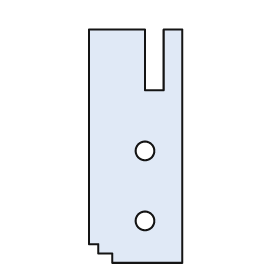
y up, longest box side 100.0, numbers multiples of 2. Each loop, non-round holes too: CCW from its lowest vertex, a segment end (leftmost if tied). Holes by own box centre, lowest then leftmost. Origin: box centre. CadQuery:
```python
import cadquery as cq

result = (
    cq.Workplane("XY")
    .moveTo(-10.0, -50.0)
    .lineTo(20.0, -50.0)
    .lineTo(20.0, 50.0)
    .lineTo(12.0, 50.0)
    .lineTo(12.0, 24.0)
    .lineTo(4.0, 24.0)
    .lineTo(4.0, 50.0)
    .lineTo(-20.0, 50.0)
    .lineTo(-20.0, -42.0)
    .lineTo(-16.0, -42.0)
    .lineTo(-16.0, -46.0)
    .lineTo(-10.0, -46.0)
    .close()
    .moveTo(4.0, -32.0)
    .circle(4.0)
    .moveTo(4.0, -2.0)
    .circle(4.0)
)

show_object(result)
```